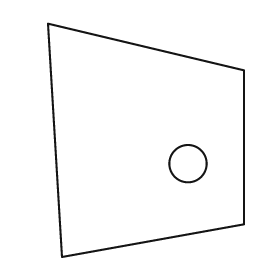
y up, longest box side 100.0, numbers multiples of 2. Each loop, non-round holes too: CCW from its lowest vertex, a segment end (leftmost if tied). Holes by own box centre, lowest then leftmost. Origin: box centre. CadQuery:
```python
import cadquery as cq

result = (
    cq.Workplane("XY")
    .moveTo(-36.0, -50.0)
    .lineTo(42.0, -36.0)
    .lineTo(42.0, 30.0)
    .lineTo(-42.0, 50.0)
    .close()
    .moveTo(18.0, -10.0)
    .circle(8.0)
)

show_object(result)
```